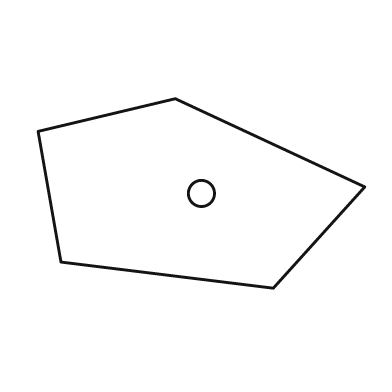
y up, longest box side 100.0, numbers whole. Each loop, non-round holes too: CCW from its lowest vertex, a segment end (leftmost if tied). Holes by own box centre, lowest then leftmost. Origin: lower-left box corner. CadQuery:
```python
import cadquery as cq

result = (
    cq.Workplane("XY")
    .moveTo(72.0, 0.0)
    .lineTo(100.0, 31.0)
    .lineTo(42.0, 58.0)
    .lineTo(0.0, 48.0)
    .lineTo(7.0, 8.0)
    .close()
    .moveTo(50.0, 29.0)
    .circle(4.0)
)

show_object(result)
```